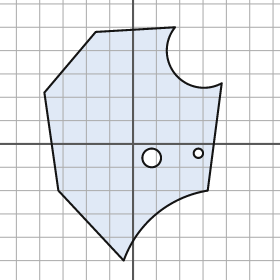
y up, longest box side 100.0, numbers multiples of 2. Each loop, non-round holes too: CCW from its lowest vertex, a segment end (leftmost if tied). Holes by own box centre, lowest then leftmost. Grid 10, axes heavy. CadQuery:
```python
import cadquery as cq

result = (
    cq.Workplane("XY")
    .moveTo(-4.0, -50.0)
    .threePointArc((10.0, -30.0), (32.0, -20.0))
    .lineTo(38.0, 26.0)
    .threePointArc((18.0, 30.0), (18.0, 50.0))
    .lineTo(-16.0, 48.0)
    .lineTo(-38.0, 22.0)
    .lineTo(-32.0, -20.0)
    .close()
    .moveTo(8.0, -6.0)
    .circle(4.0)
    .moveTo(28.0, -4.0)
    .circle(2.0)
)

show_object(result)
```